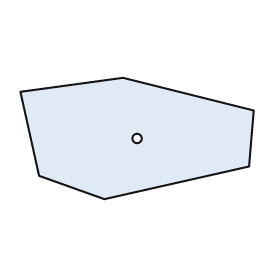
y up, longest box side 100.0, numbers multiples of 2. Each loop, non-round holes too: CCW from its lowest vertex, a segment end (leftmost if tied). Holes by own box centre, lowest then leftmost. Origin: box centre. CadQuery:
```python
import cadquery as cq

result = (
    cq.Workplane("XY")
    .moveTo(-14.0, -26.0)
    .lineTo(48.0, -12.0)
    .lineTo(50.0, 12.0)
    .lineTo(-6.0, 26.0)
    .lineTo(-50.0, 20.0)
    .lineTo(-42.0, -16.0)
    .close()
    .moveTo(0.0, 0.0)
    .circle(2.0)
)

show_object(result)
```